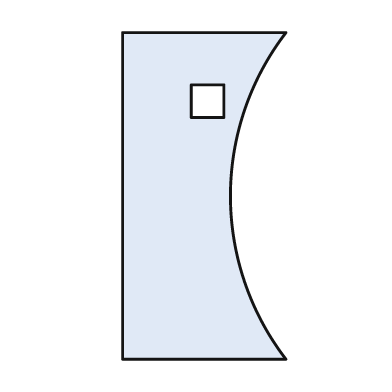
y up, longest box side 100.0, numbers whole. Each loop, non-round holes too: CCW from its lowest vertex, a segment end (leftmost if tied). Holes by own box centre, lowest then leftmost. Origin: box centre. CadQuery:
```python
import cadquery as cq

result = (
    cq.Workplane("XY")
    .moveTo(-25.0, -50.0)
    .lineTo(25.0, -50.0)
    .threePointArc((8.0, 0.0), (25.0, 50.0))
    .lineTo(-25.0, 50.0)
    .close()
    .moveTo(-4.0, 24.0)
    .lineTo(6.0, 24.0)
    .lineTo(6.0, 34.0)
    .lineTo(-4.0, 34.0)
    .close()
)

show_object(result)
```